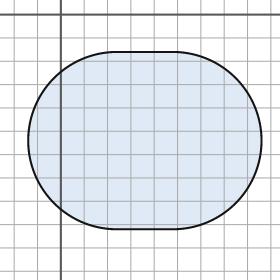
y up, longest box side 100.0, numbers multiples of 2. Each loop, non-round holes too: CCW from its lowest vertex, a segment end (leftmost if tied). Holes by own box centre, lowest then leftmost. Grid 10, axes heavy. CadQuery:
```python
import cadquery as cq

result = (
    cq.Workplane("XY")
    .moveTo(24.0, -92.0)
    .lineTo(48.0, -92.0)
    .threePointArc((86.0, -54.0), (48.0, -16.0))
    .lineTo(24.0, -16.0)
    .threePointArc((-14.0, -54.0), (24.0, -92.0))
    .close()
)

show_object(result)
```